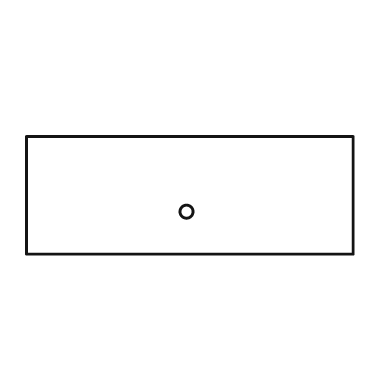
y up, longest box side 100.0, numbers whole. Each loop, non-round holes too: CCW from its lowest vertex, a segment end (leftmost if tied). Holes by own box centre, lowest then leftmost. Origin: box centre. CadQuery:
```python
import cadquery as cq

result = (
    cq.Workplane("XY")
    .moveTo(-50.0, -18.0)
    .lineTo(50.0, -18.0)
    .lineTo(50.0, 18.0)
    .lineTo(-50.0, 18.0)
    .close()
    .moveTo(-1.0, -5.0)
    .circle(2.0)
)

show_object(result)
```